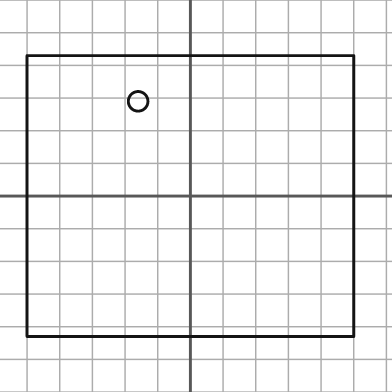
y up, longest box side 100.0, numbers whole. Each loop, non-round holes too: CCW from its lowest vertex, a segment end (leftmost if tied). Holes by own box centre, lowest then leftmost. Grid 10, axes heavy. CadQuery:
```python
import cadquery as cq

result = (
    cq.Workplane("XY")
    .moveTo(-50.0, -43.0)
    .lineTo(50.0, -43.0)
    .lineTo(50.0, 43.0)
    .lineTo(-50.0, 43.0)
    .close()
    .moveTo(-16.0, 29.0)
    .circle(3.0)
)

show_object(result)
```